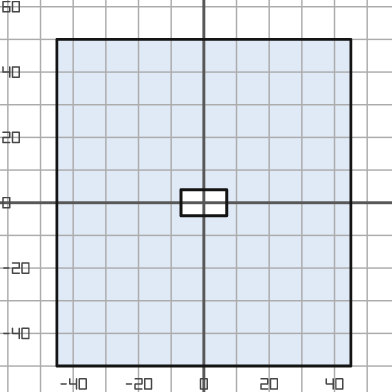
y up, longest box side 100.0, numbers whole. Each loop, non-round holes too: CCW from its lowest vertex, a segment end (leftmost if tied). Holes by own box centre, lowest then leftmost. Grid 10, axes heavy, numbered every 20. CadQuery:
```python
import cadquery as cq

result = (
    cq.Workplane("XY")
    .moveTo(-45.0, -50.0)
    .lineTo(45.0, -50.0)
    .lineTo(45.0, 50.0)
    .lineTo(-45.0, 50.0)
    .close()
    .moveTo(-7.0, -4.0)
    .lineTo(7.0, -4.0)
    .lineTo(7.0, 4.0)
    .lineTo(-7.0, 4.0)
    .close()
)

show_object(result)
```